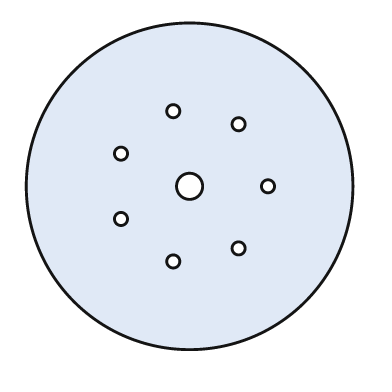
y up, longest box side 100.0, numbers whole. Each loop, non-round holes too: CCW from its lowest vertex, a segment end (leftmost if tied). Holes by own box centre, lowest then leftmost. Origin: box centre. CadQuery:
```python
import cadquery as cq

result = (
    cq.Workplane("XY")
    .moveTo(0.0, 0.0)
    .circle(50.0)
    .moveTo(-5.0, -23.0)
    .circle(2.0)
    .moveTo(15.0, -19.0)
    .circle(2.0)
    .moveTo(-21.0, -10.0)
    .circle(2.0)
    .moveTo(0.0, 0.0)
    .circle(4.0)
    .moveTo(24.0, 0.0)
    .circle(2.0)
    .moveTo(-21.0, 10.0)
    .circle(2.0)
    .moveTo(15.0, 19.0)
    .circle(2.0)
    .moveTo(-5.0, 23.0)
    .circle(2.0)
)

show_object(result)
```